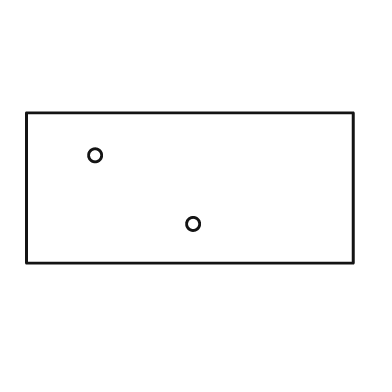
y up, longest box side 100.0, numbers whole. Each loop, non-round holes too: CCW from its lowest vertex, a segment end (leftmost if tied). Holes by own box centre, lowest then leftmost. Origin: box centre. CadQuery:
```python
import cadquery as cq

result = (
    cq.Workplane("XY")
    .moveTo(-50.0, -23.0)
    .lineTo(50.0, -23.0)
    .lineTo(50.0, 23.0)
    .lineTo(-50.0, 23.0)
    .close()
    .moveTo(1.0, -11.0)
    .circle(2.0)
    .moveTo(-29.0, 10.0)
    .circle(2.0)
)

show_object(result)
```